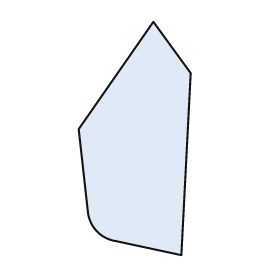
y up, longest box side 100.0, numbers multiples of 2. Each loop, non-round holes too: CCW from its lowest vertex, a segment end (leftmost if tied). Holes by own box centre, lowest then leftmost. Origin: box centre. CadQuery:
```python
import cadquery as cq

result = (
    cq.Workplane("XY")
    .moveTo(20.0, -50.0)
    .lineTo(24.0, 28.0)
    .lineTo(8.0, 50.0)
    .lineTo(-24.0, 4.0)
    .lineTo(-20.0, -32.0)
    .threePointArc((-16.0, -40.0), (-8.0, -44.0))
    .close()
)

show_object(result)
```